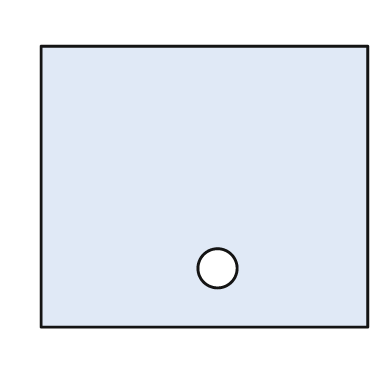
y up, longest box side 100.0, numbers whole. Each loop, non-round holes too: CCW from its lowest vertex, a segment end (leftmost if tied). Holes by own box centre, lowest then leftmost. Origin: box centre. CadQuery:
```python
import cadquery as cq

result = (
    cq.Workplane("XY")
    .moveTo(-50.0, -43.0)
    .lineTo(50.0, -43.0)
    .lineTo(50.0, 43.0)
    .lineTo(-50.0, 43.0)
    .close()
    .moveTo(4.0, -25.0)
    .circle(6.0)
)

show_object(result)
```